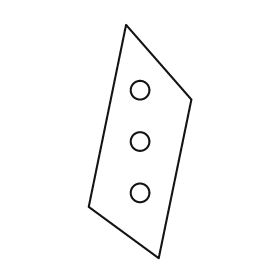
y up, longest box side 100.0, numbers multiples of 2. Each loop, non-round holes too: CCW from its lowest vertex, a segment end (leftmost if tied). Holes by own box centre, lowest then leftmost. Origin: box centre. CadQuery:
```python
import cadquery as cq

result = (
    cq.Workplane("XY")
    .moveTo(8.0, -50.0)
    .lineTo(22.0, 18.0)
    .lineTo(-6.0, 50.0)
    .lineTo(-22.0, -28.0)
    .close()
    .moveTo(0.0, -22.0)
    .circle(4.0)
    .moveTo(0.0, 0.0)
    .circle(4.0)
    .moveTo(0.0, 22.0)
    .circle(4.0)
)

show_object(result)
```